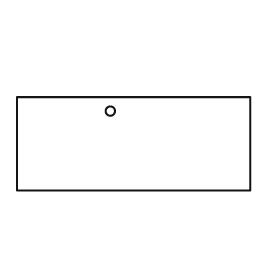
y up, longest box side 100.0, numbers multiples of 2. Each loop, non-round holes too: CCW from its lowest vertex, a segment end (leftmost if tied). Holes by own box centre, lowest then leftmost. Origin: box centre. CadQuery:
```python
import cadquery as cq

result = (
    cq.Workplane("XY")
    .moveTo(-50.0, -20.0)
    .lineTo(50.0, -20.0)
    .lineTo(50.0, 20.0)
    .lineTo(-50.0, 20.0)
    .close()
    .moveTo(-10.0, 14.0)
    .circle(2.0)
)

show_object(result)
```